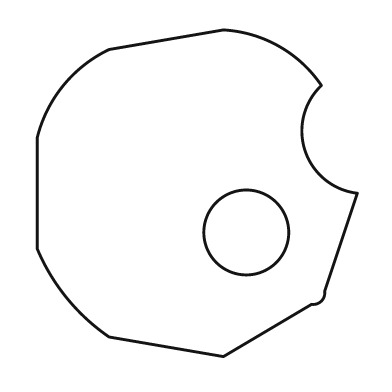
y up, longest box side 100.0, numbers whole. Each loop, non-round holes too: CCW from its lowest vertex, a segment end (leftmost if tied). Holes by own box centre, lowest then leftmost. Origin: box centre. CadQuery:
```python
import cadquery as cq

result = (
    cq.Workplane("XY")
    .moveTo(8.0, -50.0)
    .lineTo(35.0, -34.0)
    .threePointArc((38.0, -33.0), (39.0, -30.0))
    .lineTo(49.0, 0.0)
    .threePointArc((33.0, 13.0), (38.0, 33.0))
    .threePointArc((25.0, 45.0), (8.0, 50.0))
    .lineTo(-27.0, 44.0)
    .threePointArc((-41.0, 33.0), (-49.0, 17.0))
    .lineTo(-49.0, -17.0)
    .threePointArc((-40.0, -32.0), (-27.0, -44.0))
    .close()
    .moveTo(15.0, -12.0)
    .circle(13.0)
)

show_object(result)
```